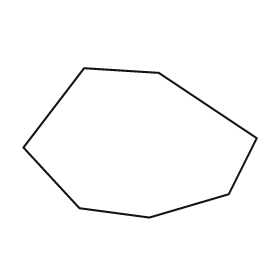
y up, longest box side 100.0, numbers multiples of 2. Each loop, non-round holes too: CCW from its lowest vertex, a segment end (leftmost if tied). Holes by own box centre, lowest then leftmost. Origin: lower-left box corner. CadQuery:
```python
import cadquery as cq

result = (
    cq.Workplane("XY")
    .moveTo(54.0, 0.0)
    .lineTo(88.0, 10.0)
    .lineTo(100.0, 34.0)
    .lineTo(58.0, 62.0)
    .lineTo(26.0, 64.0)
    .lineTo(0.0, 30.0)
    .lineTo(24.0, 4.0)
    .close()
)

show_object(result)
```